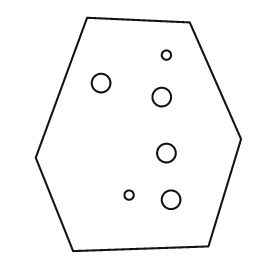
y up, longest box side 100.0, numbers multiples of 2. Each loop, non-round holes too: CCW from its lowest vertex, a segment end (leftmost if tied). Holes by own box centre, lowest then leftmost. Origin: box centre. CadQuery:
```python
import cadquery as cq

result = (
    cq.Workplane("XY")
    .moveTo(-28.0, -50.0)
    .lineTo(30.0, -48.0)
    .lineTo(44.0, -2.0)
    .lineTo(22.0, 48.0)
    .lineTo(-22.0, 50.0)
    .lineTo(-44.0, -10.0)
    .close()
    .moveTo(14.0, -28.0)
    .circle(4.0)
    .moveTo(-4.0, -26.0)
    .circle(2.0)
    .moveTo(12.0, -8.0)
    .circle(4.0)
    .moveTo(10.0, 16.0)
    .circle(4.0)
    .moveTo(-16.0, 22.0)
    .circle(4.0)
    .moveTo(12.0, 34.0)
    .circle(2.0)
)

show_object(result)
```